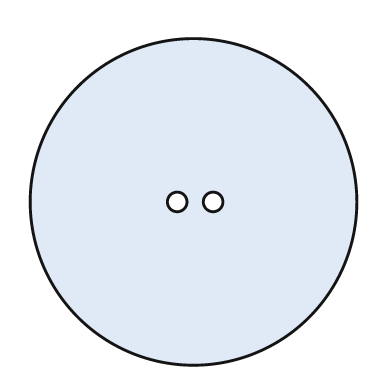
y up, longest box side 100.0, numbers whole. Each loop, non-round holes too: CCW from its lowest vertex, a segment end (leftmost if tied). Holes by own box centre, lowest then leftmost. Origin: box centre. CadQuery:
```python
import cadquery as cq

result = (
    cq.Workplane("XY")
    .moveTo(0.0, 0.0)
    .circle(50.0)
    .moveTo(-5.0, 0.0)
    .circle(3.0)
    .moveTo(6.0, 0.0)
    .circle(3.0)
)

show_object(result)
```